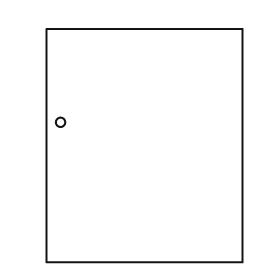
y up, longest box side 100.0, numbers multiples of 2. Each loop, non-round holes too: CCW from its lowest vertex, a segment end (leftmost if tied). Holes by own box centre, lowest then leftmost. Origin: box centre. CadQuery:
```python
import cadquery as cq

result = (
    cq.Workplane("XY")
    .moveTo(-42.0, -50.0)
    .lineTo(42.0, -50.0)
    .lineTo(42.0, 50.0)
    .lineTo(-42.0, 50.0)
    .close()
    .moveTo(-36.0, 10.0)
    .circle(2.0)
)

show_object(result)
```